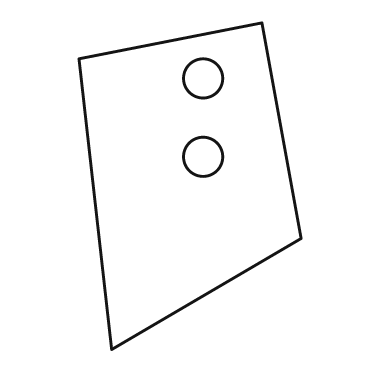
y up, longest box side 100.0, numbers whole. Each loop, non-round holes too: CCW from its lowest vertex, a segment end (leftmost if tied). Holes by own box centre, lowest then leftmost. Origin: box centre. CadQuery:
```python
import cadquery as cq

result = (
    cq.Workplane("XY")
    .moveTo(-24.0, -50.0)
    .lineTo(34.0, -16.0)
    .lineTo(22.0, 50.0)
    .lineTo(-34.0, 39.0)
    .close()
    .moveTo(4.0, 9.0)
    .circle(6.0)
    .moveTo(4.0, 33.0)
    .circle(6.0)
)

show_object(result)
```